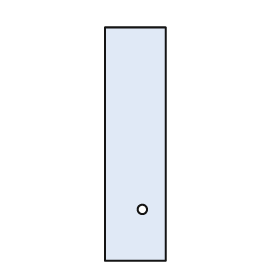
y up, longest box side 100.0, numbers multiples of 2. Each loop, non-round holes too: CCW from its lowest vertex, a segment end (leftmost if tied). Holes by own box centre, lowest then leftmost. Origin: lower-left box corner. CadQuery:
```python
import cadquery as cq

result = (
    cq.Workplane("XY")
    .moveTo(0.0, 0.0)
    .lineTo(26.0, 0.0)
    .lineTo(26.0, 100.0)
    .lineTo(0.0, 100.0)
    .close()
    .moveTo(16.0, 22.0)
    .circle(2.0)
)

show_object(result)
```